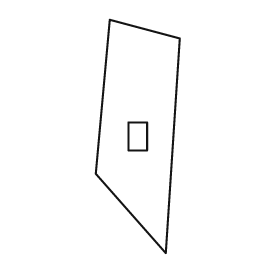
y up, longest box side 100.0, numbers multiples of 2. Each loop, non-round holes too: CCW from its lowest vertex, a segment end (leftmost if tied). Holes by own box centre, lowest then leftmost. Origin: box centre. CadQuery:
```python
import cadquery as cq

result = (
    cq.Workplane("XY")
    .moveTo(12.0, -50.0)
    .lineTo(18.0, 42.0)
    .lineTo(-12.0, 50.0)
    .lineTo(-18.0, -16.0)
    .close()
    .moveTo(-4.0, -6.0)
    .lineTo(4.0, -6.0)
    .lineTo(4.0, 6.0)
    .lineTo(-4.0, 6.0)
    .close()
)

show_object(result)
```